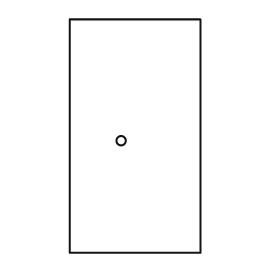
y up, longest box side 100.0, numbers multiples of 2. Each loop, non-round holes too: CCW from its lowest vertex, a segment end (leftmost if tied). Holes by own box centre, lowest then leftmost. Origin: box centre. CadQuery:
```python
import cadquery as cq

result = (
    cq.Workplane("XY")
    .moveTo(-28.0, -50.0)
    .lineTo(28.0, -50.0)
    .lineTo(28.0, 50.0)
    .lineTo(-28.0, 50.0)
    .close()
    .moveTo(-6.0, -2.0)
    .circle(2.0)
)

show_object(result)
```